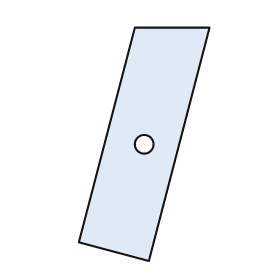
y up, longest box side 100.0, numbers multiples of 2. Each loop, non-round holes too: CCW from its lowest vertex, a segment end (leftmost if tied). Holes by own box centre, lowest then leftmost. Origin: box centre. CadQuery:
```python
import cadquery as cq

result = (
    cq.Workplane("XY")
    .moveTo(2.0, -50.0)
    .lineTo(28.0, 50.0)
    .lineTo(-4.0, 50.0)
    .lineTo(-28.0, -42.0)
    .close()
    .moveTo(0.0, 0.0)
    .circle(4.0)
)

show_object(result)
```